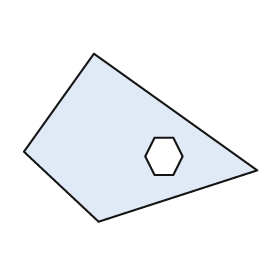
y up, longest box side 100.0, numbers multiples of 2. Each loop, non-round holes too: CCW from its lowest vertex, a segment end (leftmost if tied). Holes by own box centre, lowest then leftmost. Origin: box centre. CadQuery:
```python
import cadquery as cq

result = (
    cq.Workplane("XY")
    .moveTo(-18.0, -36.0)
    .lineTo(50.0, -14.0)
    .lineTo(-20.0, 36.0)
    .lineTo(-50.0, -6.0)
    .close()
    .moveTo(6.0, -16.0)
    .lineTo(14.0, -16.0)
    .lineTo(18.0, -8.0)
    .lineTo(14.0, 0.0)
    .lineTo(6.0, 0.0)
    .lineTo(2.0, -8.0)
    .close()
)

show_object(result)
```